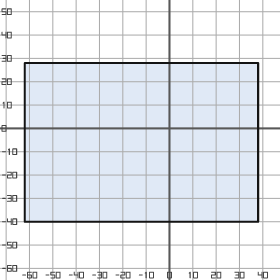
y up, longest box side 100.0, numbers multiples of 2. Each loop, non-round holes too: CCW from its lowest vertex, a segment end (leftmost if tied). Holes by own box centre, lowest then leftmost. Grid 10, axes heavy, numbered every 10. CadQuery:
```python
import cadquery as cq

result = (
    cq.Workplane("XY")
    .moveTo(-62.0, -40.0)
    .lineTo(38.0, -40.0)
    .lineTo(38.0, 28.0)
    .lineTo(-62.0, 28.0)
    .close()
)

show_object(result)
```